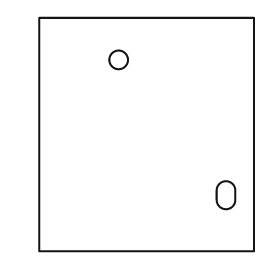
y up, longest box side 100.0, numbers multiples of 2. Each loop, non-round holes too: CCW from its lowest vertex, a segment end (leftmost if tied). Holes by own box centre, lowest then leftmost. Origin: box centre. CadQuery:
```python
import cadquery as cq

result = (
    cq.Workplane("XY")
    .moveTo(-46.0, -50.0)
    .lineTo(46.0, -50.0)
    .lineTo(46.0, 50.0)
    .lineTo(-46.0, 50.0)
    .close()
    .moveTo(30.0, -28.0)
    .threePointArc((34.0, -32.0), (38.0, -28.0))
    .lineTo(38.0, -24.0)
    .threePointArc((34.0, -20.0), (30.0, -24.0))
    .close()
    .moveTo(-12.0, 32.0)
    .circle(4.0)
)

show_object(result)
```